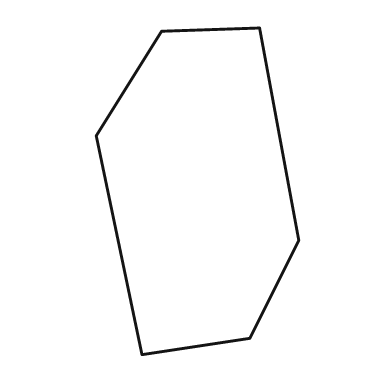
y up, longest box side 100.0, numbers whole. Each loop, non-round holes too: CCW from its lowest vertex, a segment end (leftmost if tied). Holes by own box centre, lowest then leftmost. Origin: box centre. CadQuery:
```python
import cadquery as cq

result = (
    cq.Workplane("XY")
    .moveTo(-17.0, -50.0)
    .lineTo(16.0, -45.0)
    .lineTo(31.0, -15.0)
    .lineTo(19.0, 50.0)
    .lineTo(-11.0, 49.0)
    .lineTo(-31.0, 17.0)
    .close()
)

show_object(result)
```